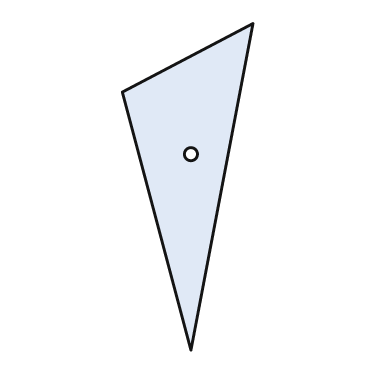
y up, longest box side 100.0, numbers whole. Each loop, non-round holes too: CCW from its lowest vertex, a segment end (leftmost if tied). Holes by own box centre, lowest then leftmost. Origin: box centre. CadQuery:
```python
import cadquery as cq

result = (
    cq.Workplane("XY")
    .moveTo(1.0, -50.0)
    .lineTo(20.0, 50.0)
    .lineTo(-20.0, 29.0)
    .close()
    .moveTo(1.0, 10.0)
    .circle(2.0)
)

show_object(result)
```